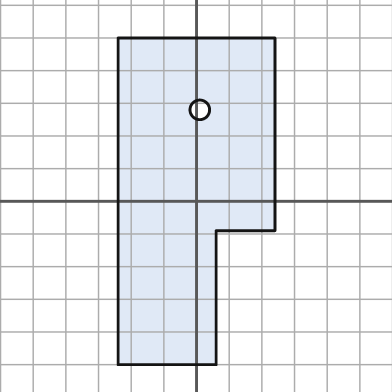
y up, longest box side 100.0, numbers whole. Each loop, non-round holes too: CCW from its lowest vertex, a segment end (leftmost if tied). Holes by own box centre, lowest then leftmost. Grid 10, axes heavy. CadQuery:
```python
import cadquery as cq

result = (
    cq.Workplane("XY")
    .moveTo(-24.0, -50.0)
    .lineTo(6.0, -50.0)
    .lineTo(6.0, -9.0)
    .lineTo(24.0, -9.0)
    .lineTo(24.0, 50.0)
    .lineTo(-24.0, 50.0)
    .close()
    .moveTo(1.0, 28.0)
    .circle(3.0)
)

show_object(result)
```